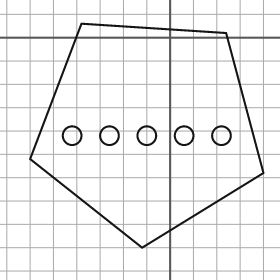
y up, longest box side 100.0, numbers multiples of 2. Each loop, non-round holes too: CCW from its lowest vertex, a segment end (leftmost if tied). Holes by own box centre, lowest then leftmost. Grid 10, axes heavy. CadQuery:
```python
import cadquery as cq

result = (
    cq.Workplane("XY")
    .moveTo(-12.0, -90.0)
    .lineTo(40.0, -58.0)
    .lineTo(24.0, 2.0)
    .lineTo(-38.0, 6.0)
    .lineTo(-60.0, -52.0)
    .close()
    .moveTo(-42.0, -42.0)
    .circle(4.0)
    .moveTo(-26.0, -42.0)
    .circle(4.0)
    .moveTo(-10.0, -42.0)
    .circle(4.0)
    .moveTo(6.0, -42.0)
    .circle(4.0)
    .moveTo(22.0, -42.0)
    .circle(4.0)
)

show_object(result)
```